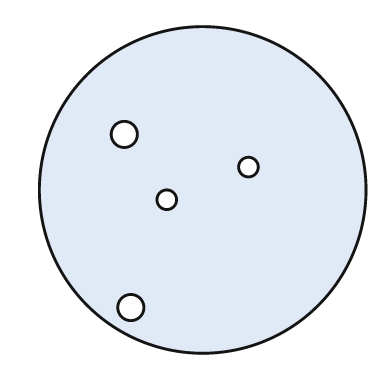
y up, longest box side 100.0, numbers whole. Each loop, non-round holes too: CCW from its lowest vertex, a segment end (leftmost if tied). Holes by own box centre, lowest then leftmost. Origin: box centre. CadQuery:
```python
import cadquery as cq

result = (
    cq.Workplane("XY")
    .moveTo(0.0, 0.0)
    .circle(50.0)
    .moveTo(-22.0, -36.0)
    .circle(4.0)
    .moveTo(-11.0, -3.0)
    .circle(3.0)
    .moveTo(14.0, 7.0)
    .circle(3.0)
    .moveTo(-24.0, 17.0)
    .circle(4.0)
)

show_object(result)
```